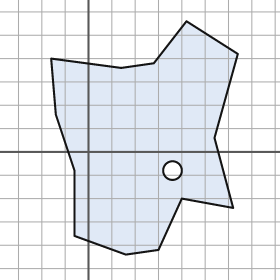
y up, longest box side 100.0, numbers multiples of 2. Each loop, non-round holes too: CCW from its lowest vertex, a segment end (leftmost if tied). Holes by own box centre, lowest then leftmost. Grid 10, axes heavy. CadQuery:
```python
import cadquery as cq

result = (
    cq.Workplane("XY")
    .moveTo(16.0, -44.0)
    .lineTo(30.0, -42.0)
    .lineTo(40.0, -20.0)
    .lineTo(62.0, -24.0)
    .lineTo(54.0, 6.0)
    .lineTo(64.0, 42.0)
    .lineTo(42.0, 56.0)
    .lineTo(28.0, 38.0)
    .lineTo(14.0, 36.0)
    .lineTo(-16.0, 40.0)
    .lineTo(-14.0, 16.0)
    .lineTo(-6.0, -8.0)
    .lineTo(-6.0, -36.0)
    .close()
    .moveTo(36.0, -8.0)
    .circle(4.0)
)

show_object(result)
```